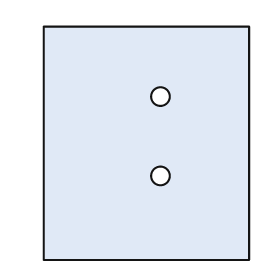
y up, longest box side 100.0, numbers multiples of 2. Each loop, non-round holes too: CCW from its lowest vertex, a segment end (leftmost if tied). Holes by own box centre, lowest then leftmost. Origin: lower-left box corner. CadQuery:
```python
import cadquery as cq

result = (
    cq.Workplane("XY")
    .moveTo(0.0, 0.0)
    .lineTo(88.0, 0.0)
    .lineTo(88.0, 100.0)
    .lineTo(0.0, 100.0)
    .close()
    .moveTo(50.0, 36.0)
    .circle(4.0)
    .moveTo(50.0, 70.0)
    .circle(4.0)
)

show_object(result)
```